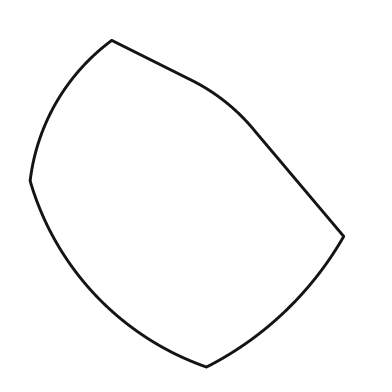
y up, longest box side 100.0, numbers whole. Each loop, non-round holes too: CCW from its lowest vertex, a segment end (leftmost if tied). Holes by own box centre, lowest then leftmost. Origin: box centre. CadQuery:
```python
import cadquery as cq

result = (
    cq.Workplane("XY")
    .moveTo(6.0, -50.0)
    .threePointArc((30.0, -33.0), (48.0, -10.0))
    .lineTo(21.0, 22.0)
    .threePointArc((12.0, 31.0), (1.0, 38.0))
    .lineTo(-23.0, 50.0)
    .threePointArc((-40.0, 31.0), (-48.0, 7.0))
    .threePointArc((-28.0, -28.0), (6.0, -50.0))
    .close()
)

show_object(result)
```